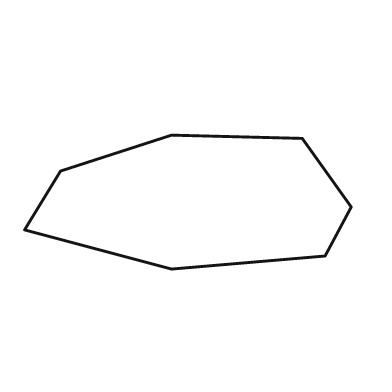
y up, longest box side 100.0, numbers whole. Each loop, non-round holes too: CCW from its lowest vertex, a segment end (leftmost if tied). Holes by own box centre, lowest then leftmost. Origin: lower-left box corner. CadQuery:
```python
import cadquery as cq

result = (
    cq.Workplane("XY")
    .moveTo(45.0, 0.0)
    .lineTo(92.0, 4.0)
    .lineTo(100.0, 19.0)
    .lineTo(85.0, 40.0)
    .lineTo(45.0, 41.0)
    .lineTo(11.0, 30.0)
    .lineTo(0.0, 12.0)
    .close()
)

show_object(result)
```